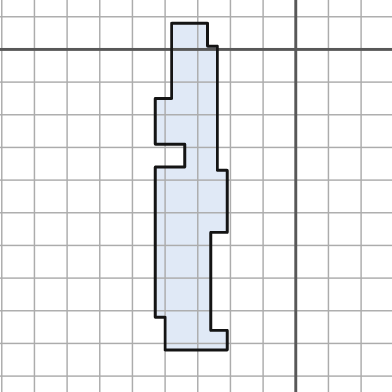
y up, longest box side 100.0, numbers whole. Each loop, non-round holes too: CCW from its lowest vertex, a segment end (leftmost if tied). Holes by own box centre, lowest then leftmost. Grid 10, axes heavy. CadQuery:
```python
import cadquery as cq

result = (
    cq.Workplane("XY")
    .moveTo(-40.0, -92.0)
    .lineTo(-21.0, -92.0)
    .lineTo(-21.0, -86.0)
    .lineTo(-26.0, -86.0)
    .lineTo(-26.0, -56.0)
    .lineTo(-21.0, -56.0)
    .lineTo(-21.0, -37.0)
    .lineTo(-24.0, -37.0)
    .lineTo(-24.0, 1.0)
    .lineTo(-27.0, 1.0)
    .lineTo(-27.0, 8.0)
    .lineTo(-38.0, 8.0)
    .lineTo(-38.0, -15.0)
    .lineTo(-43.0, -15.0)
    .lineTo(-43.0, -29.0)
    .lineTo(-34.0, -29.0)
    .lineTo(-34.0, -36.0)
    .lineTo(-43.0, -36.0)
    .lineTo(-43.0, -82.0)
    .lineTo(-40.0, -82.0)
    .close()
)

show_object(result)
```